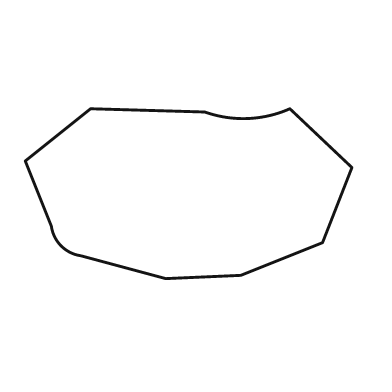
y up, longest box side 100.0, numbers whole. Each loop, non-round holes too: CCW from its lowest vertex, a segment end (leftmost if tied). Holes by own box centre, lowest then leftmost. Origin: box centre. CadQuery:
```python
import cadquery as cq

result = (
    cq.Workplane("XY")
    .moveTo(-7.0, -26.0)
    .lineTo(16.0, -25.0)
    .lineTo(41.0, -15.0)
    .lineTo(50.0, 8.0)
    .lineTo(31.0, 26.0)
    .threePointArc((18.0, 23.0), (5.0, 25.0))
    .lineTo(-30.0, 26.0)
    .lineTo(-50.0, 10.0)
    .lineTo(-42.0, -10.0)
    .threePointArc((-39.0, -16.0), (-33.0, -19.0))
    .close()
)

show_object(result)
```